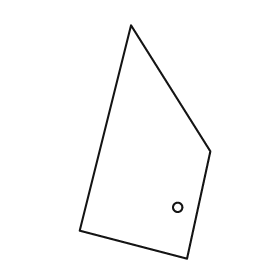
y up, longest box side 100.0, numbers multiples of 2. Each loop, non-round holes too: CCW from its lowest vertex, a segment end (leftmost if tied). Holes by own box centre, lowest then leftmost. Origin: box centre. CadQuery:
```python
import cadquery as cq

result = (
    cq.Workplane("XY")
    .moveTo(18.0, -50.0)
    .lineTo(28.0, -4.0)
    .lineTo(-6.0, 50.0)
    .lineTo(-28.0, -38.0)
    .close()
    .moveTo(14.0, -28.0)
    .circle(2.0)
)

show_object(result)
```